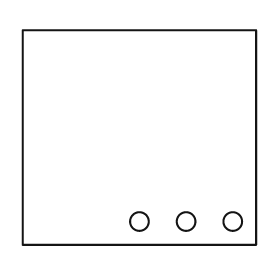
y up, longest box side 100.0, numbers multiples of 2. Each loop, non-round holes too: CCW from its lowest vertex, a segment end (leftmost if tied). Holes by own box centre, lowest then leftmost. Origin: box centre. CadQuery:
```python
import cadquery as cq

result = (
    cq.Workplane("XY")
    .moveTo(-50.0, -46.0)
    .lineTo(50.0, -46.0)
    .lineTo(50.0, 46.0)
    .lineTo(-50.0, 46.0)
    .close()
    .moveTo(0.0, -36.0)
    .circle(4.0)
    .moveTo(20.0, -36.0)
    .circle(4.0)
    .moveTo(40.0, -36.0)
    .circle(4.0)
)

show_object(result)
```